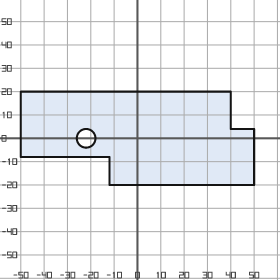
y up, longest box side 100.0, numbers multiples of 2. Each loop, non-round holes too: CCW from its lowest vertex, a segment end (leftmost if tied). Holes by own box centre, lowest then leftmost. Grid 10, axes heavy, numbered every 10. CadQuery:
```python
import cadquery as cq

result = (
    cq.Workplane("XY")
    .moveTo(-12.0, -20.0)
    .lineTo(50.0, -20.0)
    .lineTo(50.0, 4.0)
    .lineTo(40.0, 4.0)
    .lineTo(40.0, 20.0)
    .lineTo(-50.0, 20.0)
    .lineTo(-50.0, -8.0)
    .lineTo(-12.0, -8.0)
    .close()
    .moveTo(-22.0, 0.0)
    .circle(4.0)
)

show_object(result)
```